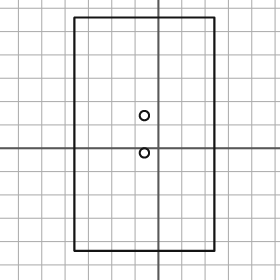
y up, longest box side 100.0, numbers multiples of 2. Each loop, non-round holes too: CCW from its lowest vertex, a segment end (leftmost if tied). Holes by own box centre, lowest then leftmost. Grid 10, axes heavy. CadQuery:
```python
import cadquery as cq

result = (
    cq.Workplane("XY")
    .moveTo(-36.0, -44.0)
    .lineTo(24.0, -44.0)
    .lineTo(24.0, 56.0)
    .lineTo(-36.0, 56.0)
    .close()
    .moveTo(-6.0, -2.0)
    .circle(2.0)
    .moveTo(-6.0, 14.0)
    .circle(2.0)
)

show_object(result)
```